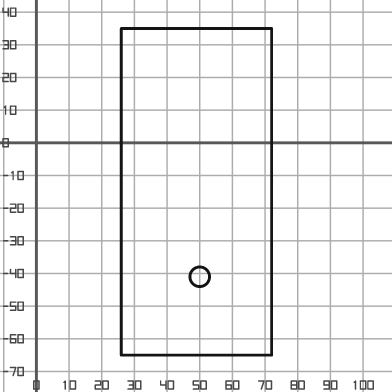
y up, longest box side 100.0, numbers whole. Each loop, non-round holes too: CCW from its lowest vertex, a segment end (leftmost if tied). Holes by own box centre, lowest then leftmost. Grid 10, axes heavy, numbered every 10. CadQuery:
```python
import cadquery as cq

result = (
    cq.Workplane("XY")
    .moveTo(26.0, -65.0)
    .lineTo(72.0, -65.0)
    .lineTo(72.0, 35.0)
    .lineTo(26.0, 35.0)
    .close()
    .moveTo(50.0, -41.0)
    .circle(3.0)
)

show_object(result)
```